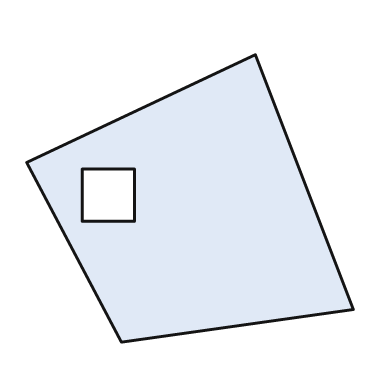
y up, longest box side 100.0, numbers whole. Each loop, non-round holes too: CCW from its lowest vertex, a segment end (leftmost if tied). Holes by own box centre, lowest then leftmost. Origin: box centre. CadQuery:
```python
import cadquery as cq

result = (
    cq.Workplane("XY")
    .moveTo(-21.0, -44.0)
    .lineTo(50.0, -34.0)
    .lineTo(20.0, 44.0)
    .lineTo(-50.0, 11.0)
    .close()
    .moveTo(-33.0, -7.0)
    .lineTo(-17.0, -7.0)
    .lineTo(-17.0, 9.0)
    .lineTo(-33.0, 9.0)
    .close()
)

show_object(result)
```